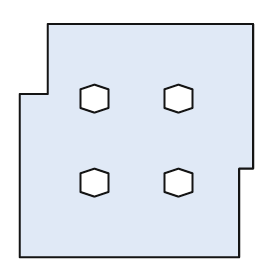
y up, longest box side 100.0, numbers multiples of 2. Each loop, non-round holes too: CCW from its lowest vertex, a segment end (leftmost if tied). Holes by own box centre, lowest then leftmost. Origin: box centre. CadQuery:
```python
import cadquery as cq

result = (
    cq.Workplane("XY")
    .moveTo(-50.0, -50.0)
    .lineTo(44.0, -50.0)
    .lineTo(44.0, -12.0)
    .lineTo(50.0, -12.0)
    .lineTo(50.0, 50.0)
    .lineTo(-38.0, 50.0)
    .lineTo(-38.0, 20.0)
    .lineTo(-50.0, 20.0)
    .close()
    .moveTo(-18.0, -24.0)
    .lineTo(-12.0, -22.0)
    .lineTo(-12.0, -14.0)
    .lineTo(-18.0, -12.0)
    .lineTo(-24.0, -14.0)
    .lineTo(-24.0, -22.0)
    .close()
    .moveTo(18.0, -24.0)
    .lineTo(24.0, -22.0)
    .lineTo(24.0, -14.0)
    .lineTo(18.0, -12.0)
    .lineTo(12.0, -14.0)
    .lineTo(12.0, -22.0)
    .close()
    .moveTo(-18.0, 12.0)
    .lineTo(-12.0, 14.0)
    .lineTo(-12.0, 22.0)
    .lineTo(-18.0, 24.0)
    .lineTo(-24.0, 22.0)
    .lineTo(-24.0, 14.0)
    .close()
    .moveTo(18.0, 12.0)
    .lineTo(24.0, 14.0)
    .lineTo(24.0, 22.0)
    .lineTo(18.0, 24.0)
    .lineTo(12.0, 22.0)
    .lineTo(12.0, 14.0)
    .close()
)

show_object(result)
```